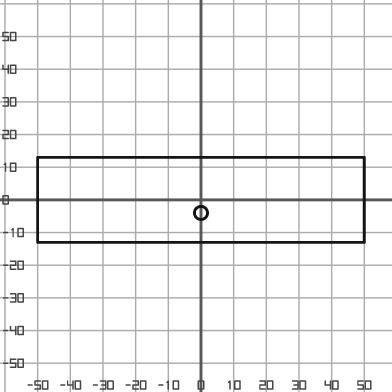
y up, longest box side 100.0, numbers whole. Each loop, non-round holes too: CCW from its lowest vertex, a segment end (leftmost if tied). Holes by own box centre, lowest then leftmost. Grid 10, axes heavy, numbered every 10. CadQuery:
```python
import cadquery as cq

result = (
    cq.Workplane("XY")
    .moveTo(-50.0, -13.0)
    .lineTo(50.0, -13.0)
    .lineTo(50.0, 13.0)
    .lineTo(-50.0, 13.0)
    .close()
    .moveTo(0.0, -4.0)
    .circle(2.0)
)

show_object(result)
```